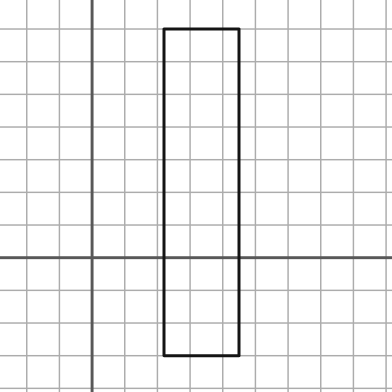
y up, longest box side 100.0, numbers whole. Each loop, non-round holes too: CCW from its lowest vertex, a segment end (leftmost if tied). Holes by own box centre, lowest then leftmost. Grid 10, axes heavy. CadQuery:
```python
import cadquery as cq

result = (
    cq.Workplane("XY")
    .moveTo(22.0, -30.0)
    .lineTo(45.0, -30.0)
    .lineTo(45.0, 70.0)
    .lineTo(22.0, 70.0)
    .close()
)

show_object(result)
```